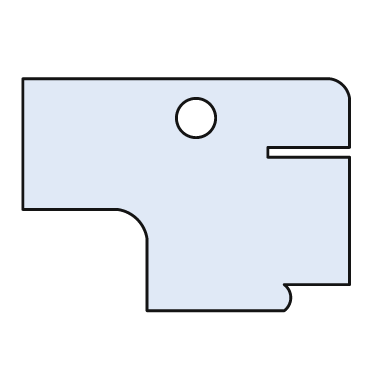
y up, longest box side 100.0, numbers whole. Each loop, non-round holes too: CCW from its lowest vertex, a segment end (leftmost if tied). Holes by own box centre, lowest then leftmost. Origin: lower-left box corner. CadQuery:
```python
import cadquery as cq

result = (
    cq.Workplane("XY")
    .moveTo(38.0, 0.0)
    .lineTo(80.0, 0.0)
    .threePointArc((82.0, 4.0), (80.0, 8.0))
    .lineTo(100.0, 8.0)
    .lineTo(100.0, 47.0)
    .lineTo(75.0, 47.0)
    .lineTo(75.0, 50.0)
    .lineTo(100.0, 50.0)
    .lineTo(100.0, 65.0)
    .threePointArc((98.0, 69.0), (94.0, 71.0))
    .lineTo(0.0, 71.0)
    .lineTo(0.0, 31.0)
    .lineTo(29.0, 31.0)
    .threePointArc((35.0, 28.0), (38.0, 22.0))
    .close()
    .moveTo(53.0, 59.0)
    .circle(6.0)
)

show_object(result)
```